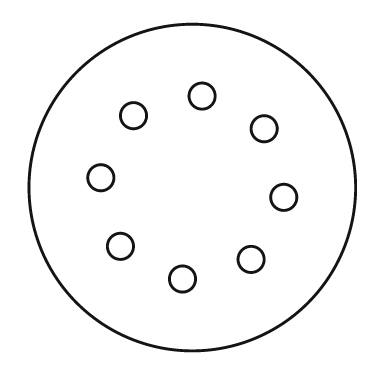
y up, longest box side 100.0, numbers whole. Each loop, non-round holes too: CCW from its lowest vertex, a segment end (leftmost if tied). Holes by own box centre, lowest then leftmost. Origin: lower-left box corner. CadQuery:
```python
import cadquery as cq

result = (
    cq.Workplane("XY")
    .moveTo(50.0, 50.0)
    .circle(50.0)
    .moveTo(47.0, 22.0)
    .circle(4.0)
    .moveTo(68.0, 28.0)
    .circle(4.0)
    .moveTo(28.0, 32.0)
    .circle(4.0)
    .moveTo(78.0, 47.0)
    .circle(4.0)
    .moveTo(22.0, 53.0)
    .circle(4.0)
    .moveTo(72.0, 68.0)
    .circle(4.0)
    .moveTo(32.0, 72.0)
    .circle(4.0)
    .moveTo(53.0, 78.0)
    .circle(4.0)
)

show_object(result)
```